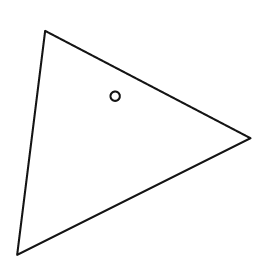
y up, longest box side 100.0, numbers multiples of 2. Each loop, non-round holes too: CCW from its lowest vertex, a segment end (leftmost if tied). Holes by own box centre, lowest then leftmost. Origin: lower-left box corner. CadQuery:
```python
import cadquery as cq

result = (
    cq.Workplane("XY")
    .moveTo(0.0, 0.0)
    .lineTo(100.0, 50.0)
    .lineTo(12.0, 96.0)
    .close()
    .moveTo(42.0, 68.0)
    .circle(2.0)
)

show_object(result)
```